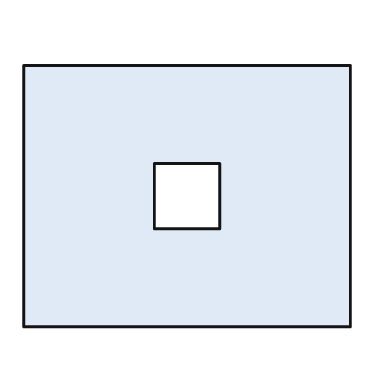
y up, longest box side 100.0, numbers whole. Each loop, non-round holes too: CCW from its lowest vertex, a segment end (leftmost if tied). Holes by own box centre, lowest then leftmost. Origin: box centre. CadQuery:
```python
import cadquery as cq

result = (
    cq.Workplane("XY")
    .moveTo(-50.0, -40.0)
    .lineTo(50.0, -40.0)
    .lineTo(50.0, 40.0)
    .lineTo(-50.0, 40.0)
    .close()
    .moveTo(-10.0, -10.0)
    .lineTo(10.0, -10.0)
    .lineTo(10.0, 10.0)
    .lineTo(-10.0, 10.0)
    .close()
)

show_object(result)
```